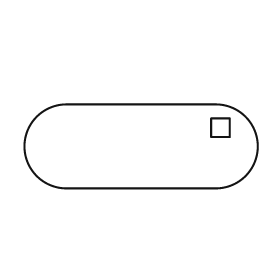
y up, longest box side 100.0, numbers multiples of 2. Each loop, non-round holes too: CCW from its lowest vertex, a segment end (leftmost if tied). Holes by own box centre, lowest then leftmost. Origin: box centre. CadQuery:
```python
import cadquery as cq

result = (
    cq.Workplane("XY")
    .moveTo(-32.0, -18.0)
    .lineTo(32.0, -18.0)
    .threePointArc((50.0, 0.0), (32.0, 18.0))
    .lineTo(-32.0, 18.0)
    .threePointArc((-50.0, 0.0), (-32.0, -18.0))
    .close()
    .moveTo(30.0, 4.0)
    .lineTo(38.0, 4.0)
    .lineTo(38.0, 12.0)
    .lineTo(30.0, 12.0)
    .close()
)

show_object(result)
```